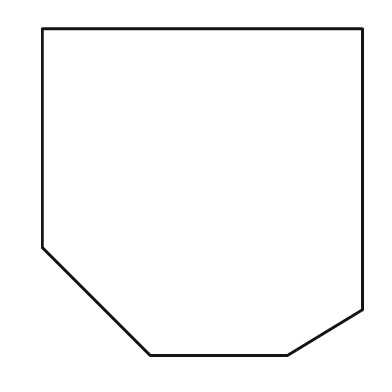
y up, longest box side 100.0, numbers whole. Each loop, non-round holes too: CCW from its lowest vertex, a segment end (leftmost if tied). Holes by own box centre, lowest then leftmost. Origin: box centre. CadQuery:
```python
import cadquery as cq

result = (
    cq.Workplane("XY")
    .moveTo(-16.0, -50.0)
    .lineTo(26.0, -50.0)
    .lineTo(49.0, -36.0)
    .lineTo(49.0, 50.0)
    .lineTo(-49.0, 50.0)
    .lineTo(-49.0, -17.0)
    .close()
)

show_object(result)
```